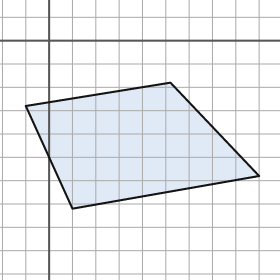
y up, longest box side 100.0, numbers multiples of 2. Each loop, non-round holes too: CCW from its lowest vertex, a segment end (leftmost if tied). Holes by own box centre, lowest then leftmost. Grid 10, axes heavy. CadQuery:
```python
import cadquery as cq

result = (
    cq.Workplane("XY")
    .moveTo(10.0, -72.0)
    .lineTo(90.0, -58.0)
    .lineTo(52.0, -18.0)
    .lineTo(-10.0, -28.0)
    .close()
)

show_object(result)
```